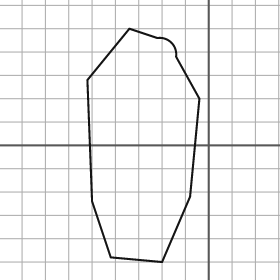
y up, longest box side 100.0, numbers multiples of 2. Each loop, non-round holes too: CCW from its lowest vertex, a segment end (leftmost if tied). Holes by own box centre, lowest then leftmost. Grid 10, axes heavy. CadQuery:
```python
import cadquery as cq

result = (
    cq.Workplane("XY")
    .moveTo(-20.0, -50.0)
    .lineTo(-8.0, -22.0)
    .lineTo(-4.0, 20.0)
    .lineTo(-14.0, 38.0)
    .threePointArc((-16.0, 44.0), (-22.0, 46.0))
    .lineTo(-34.0, 50.0)
    .lineTo(-52.0, 28.0)
    .lineTo(-50.0, -24.0)
    .lineTo(-42.0, -48.0)
    .close()
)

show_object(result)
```